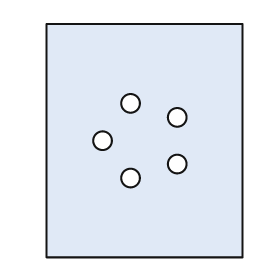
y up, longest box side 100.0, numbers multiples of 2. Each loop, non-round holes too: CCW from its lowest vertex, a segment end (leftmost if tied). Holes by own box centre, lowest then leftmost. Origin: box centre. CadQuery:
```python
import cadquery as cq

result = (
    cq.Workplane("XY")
    .moveTo(-42.0, -50.0)
    .lineTo(42.0, -50.0)
    .lineTo(42.0, 50.0)
    .lineTo(-42.0, 50.0)
    .close()
    .moveTo(-6.0, -16.0)
    .circle(4.0)
    .moveTo(14.0, -10.0)
    .circle(4.0)
    .moveTo(-18.0, 0.0)
    .circle(4.0)
    .moveTo(14.0, 10.0)
    .circle(4.0)
    .moveTo(-6.0, 16.0)
    .circle(4.0)
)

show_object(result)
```